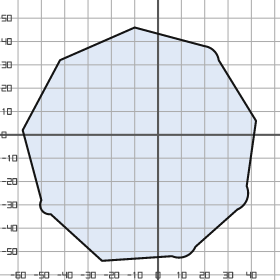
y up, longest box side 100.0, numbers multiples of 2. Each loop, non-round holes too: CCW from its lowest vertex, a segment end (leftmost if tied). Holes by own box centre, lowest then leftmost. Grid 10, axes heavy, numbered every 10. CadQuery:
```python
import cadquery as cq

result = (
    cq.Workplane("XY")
    .moveTo(-24.0, -54.0)
    .lineTo(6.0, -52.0)
    .threePointArc((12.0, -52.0), (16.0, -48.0))
    .lineTo(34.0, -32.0)
    .threePointArc((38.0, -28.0), (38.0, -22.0))
    .lineTo(42.0, 6.0)
    .lineTo(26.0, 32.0)
    .threePointArc((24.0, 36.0), (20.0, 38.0))
    .lineTo(-10.0, 46.0)
    .lineTo(-42.0, 32.0)
    .lineTo(-58.0, 2.0)
    .lineTo(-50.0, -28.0)
    .threePointArc((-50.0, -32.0), (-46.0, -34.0))
    .close()
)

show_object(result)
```